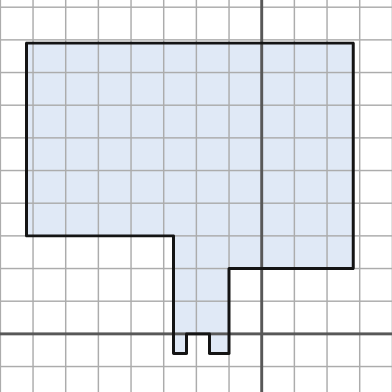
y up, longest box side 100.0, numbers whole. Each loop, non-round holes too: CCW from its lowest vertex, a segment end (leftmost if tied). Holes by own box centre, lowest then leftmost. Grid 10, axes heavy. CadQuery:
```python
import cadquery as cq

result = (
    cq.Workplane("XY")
    .moveTo(-27.0, -6.0)
    .lineTo(-23.0, -6.0)
    .lineTo(-23.0, 0.0)
    .lineTo(-16.0, 0.0)
    .lineTo(-16.0, -6.0)
    .lineTo(-10.0, -6.0)
    .lineTo(-10.0, 20.0)
    .lineTo(28.0, 20.0)
    .lineTo(28.0, 89.0)
    .lineTo(-72.0, 89.0)
    .lineTo(-72.0, 30.0)
    .lineTo(-27.0, 30.0)
    .close()
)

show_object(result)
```